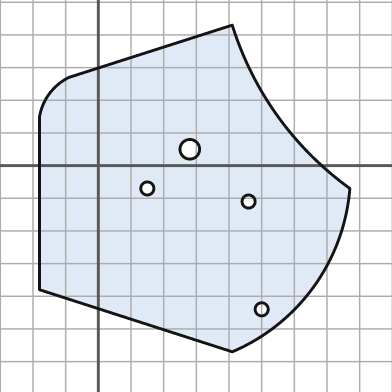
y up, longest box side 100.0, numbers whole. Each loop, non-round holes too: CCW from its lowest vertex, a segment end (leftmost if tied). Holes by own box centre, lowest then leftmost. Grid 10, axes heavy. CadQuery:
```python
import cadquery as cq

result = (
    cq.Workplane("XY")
    .moveTo(41.0, -57.0)
    .threePointArc((66.0, -37.0), (77.0, -7.0))
    .threePointArc((55.0, 15.0), (41.0, 43.0))
    .lineTo(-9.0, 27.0)
    .threePointArc((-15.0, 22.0), (-18.0, 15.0))
    .lineTo(-18.0, -38.0)
    .close()
    .moveTo(50.0, -44.0)
    .circle(2.0)
    .moveTo(46.0, -11.0)
    .circle(2.0)
    .moveTo(15.0, -7.0)
    .circle(2.0)
    .moveTo(28.0, 5.0)
    .circle(3.0)
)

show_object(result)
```